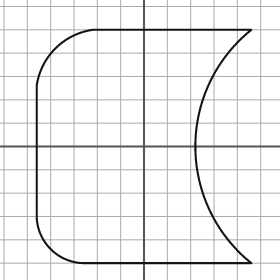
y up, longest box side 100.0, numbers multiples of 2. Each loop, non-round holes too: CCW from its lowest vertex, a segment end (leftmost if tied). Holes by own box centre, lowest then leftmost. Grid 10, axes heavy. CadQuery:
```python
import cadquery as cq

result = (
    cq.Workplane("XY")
    .moveTo(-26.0, -50.0)
    .lineTo(46.0, -50.0)
    .threePointArc((22.0, 0.0), (46.0, 50.0))
    .lineTo(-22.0, 50.0)
    .threePointArc((-38.0, 42.0), (-46.0, 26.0))
    .lineTo(-46.0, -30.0)
    .threePointArc((-40.0, -44.0), (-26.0, -50.0))
    .close()
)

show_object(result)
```